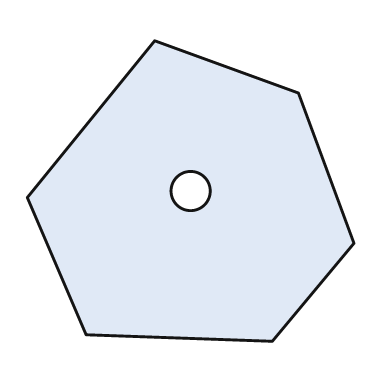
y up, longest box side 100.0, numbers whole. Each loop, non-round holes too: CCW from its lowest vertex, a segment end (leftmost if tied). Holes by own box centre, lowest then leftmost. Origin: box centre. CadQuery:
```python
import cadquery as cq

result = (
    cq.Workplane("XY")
    .moveTo(25.0, -46.0)
    .lineTo(50.0, -16.0)
    .lineTo(33.0, 30.0)
    .lineTo(-11.0, 46.0)
    .lineTo(-50.0, -2.0)
    .lineTo(-32.0, -44.0)
    .close()
    .moveTo(0.0, 0.0)
    .circle(6.0)
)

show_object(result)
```